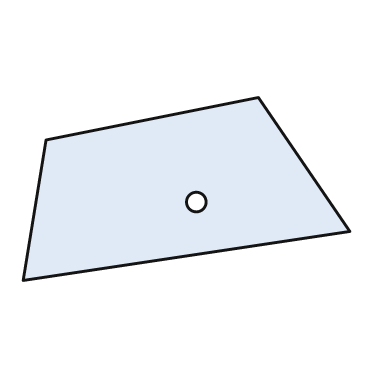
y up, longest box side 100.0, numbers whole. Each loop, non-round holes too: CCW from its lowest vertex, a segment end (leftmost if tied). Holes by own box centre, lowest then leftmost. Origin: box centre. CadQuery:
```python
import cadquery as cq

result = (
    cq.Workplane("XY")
    .moveTo(-50.0, -28.0)
    .lineTo(50.0, -13.0)
    .lineTo(22.0, 28.0)
    .lineTo(-43.0, 15.0)
    .close()
    .moveTo(3.0, -4.0)
    .circle(3.0)
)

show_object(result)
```